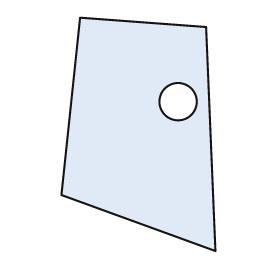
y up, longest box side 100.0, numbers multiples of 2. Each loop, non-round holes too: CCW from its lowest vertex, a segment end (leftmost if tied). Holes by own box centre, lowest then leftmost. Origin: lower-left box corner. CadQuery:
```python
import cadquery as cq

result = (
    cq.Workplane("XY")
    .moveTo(66.0, 0.0)
    .lineTo(62.0, 96.0)
    .lineTo(8.0, 100.0)
    .lineTo(0.0, 24.0)
    .close()
    .moveTo(50.0, 64.0)
    .circle(8.0)
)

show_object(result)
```